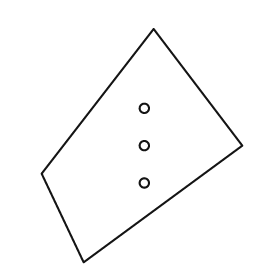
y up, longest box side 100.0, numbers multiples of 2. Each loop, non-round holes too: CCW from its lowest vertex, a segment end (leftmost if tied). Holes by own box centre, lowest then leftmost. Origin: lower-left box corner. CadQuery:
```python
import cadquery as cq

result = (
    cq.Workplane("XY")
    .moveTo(18.0, 0.0)
    .lineTo(86.0, 50.0)
    .lineTo(48.0, 100.0)
    .lineTo(0.0, 38.0)
    .close()
    .moveTo(44.0, 34.0)
    .circle(2.0)
    .moveTo(44.0, 50.0)
    .circle(2.0)
    .moveTo(44.0, 66.0)
    .circle(2.0)
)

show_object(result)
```